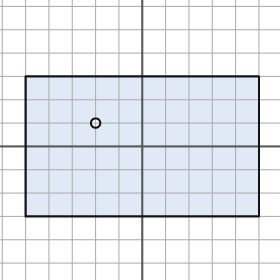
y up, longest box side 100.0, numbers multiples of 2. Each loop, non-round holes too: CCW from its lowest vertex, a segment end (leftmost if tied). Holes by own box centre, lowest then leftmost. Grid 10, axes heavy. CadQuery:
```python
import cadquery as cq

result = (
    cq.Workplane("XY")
    .moveTo(-50.0, -30.0)
    .lineTo(50.0, -30.0)
    .lineTo(50.0, 30.0)
    .lineTo(-50.0, 30.0)
    .close()
    .moveTo(-20.0, 10.0)
    .circle(2.0)
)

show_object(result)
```